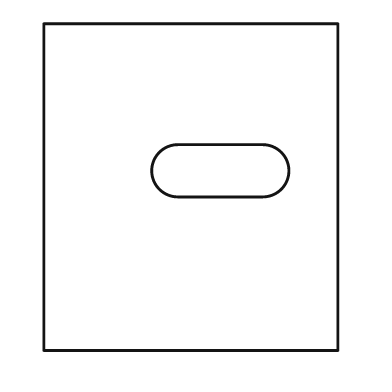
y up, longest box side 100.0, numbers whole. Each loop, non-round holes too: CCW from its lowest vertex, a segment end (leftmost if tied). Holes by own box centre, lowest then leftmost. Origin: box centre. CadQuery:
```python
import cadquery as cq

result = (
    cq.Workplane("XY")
    .moveTo(-45.0, -50.0)
    .lineTo(45.0, -50.0)
    .lineTo(45.0, 50.0)
    .lineTo(-45.0, 50.0)
    .close()
    .moveTo(-4.0, -3.0)
    .lineTo(22.0, -3.0)
    .threePointArc((30.0, 5.0), (22.0, 13.0))
    .lineTo(-4.0, 13.0)
    .threePointArc((-12.0, 5.0), (-4.0, -3.0))
    .close()
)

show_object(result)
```